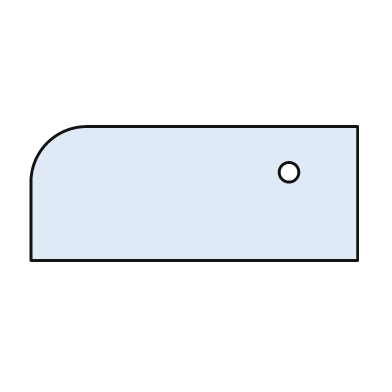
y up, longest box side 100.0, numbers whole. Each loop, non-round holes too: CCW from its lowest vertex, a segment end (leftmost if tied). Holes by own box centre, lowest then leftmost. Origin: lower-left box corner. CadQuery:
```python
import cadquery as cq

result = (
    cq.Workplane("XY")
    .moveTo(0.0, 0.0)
    .lineTo(100.0, 0.0)
    .lineTo(100.0, 41.0)
    .lineTo(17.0, 41.0)
    .threePointArc((5.0, 36.0), (0.0, 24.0))
    .close()
    .moveTo(79.0, 27.0)
    .circle(3.0)
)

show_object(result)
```